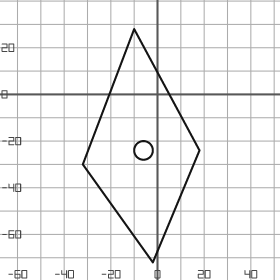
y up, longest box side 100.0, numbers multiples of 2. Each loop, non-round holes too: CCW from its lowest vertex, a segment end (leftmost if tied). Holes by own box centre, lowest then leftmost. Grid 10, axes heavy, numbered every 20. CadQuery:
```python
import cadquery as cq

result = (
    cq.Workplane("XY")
    .moveTo(-2.0, -72.0)
    .lineTo(18.0, -24.0)
    .lineTo(-10.0, 28.0)
    .lineTo(-32.0, -30.0)
    .close()
    .moveTo(-6.0, -24.0)
    .circle(4.0)
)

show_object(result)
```